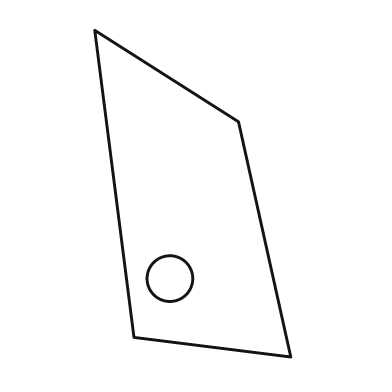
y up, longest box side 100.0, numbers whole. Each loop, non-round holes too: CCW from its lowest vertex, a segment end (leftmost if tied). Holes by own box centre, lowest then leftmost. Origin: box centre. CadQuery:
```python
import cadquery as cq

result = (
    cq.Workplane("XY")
    .moveTo(30.0, -50.0)
    .lineTo(14.0, 22.0)
    .lineTo(-30.0, 50.0)
    .lineTo(-18.0, -44.0)
    .close()
    .moveTo(-7.0, -26.0)
    .circle(7.0)
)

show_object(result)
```